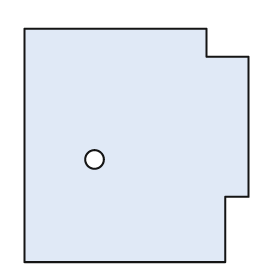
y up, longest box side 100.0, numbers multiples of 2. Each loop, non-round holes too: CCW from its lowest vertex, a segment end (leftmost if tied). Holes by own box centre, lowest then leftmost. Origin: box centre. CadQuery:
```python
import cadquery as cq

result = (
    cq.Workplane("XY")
    .moveTo(-48.0, -50.0)
    .lineTo(38.0, -50.0)
    .lineTo(38.0, -22.0)
    .lineTo(48.0, -22.0)
    .lineTo(48.0, 38.0)
    .lineTo(30.0, 38.0)
    .lineTo(30.0, 50.0)
    .lineTo(-48.0, 50.0)
    .close()
    .moveTo(-18.0, -6.0)
    .circle(4.0)
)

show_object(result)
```